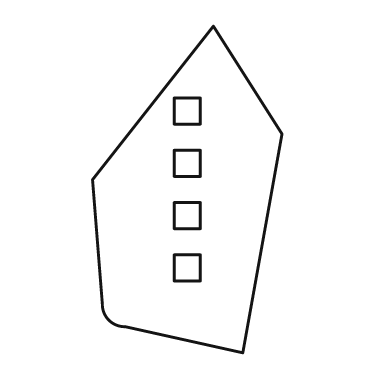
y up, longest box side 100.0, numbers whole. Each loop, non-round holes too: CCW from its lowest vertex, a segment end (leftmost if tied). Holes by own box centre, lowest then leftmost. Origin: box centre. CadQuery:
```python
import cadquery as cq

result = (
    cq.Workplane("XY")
    .moveTo(17.0, -50.0)
    .lineTo(29.0, 17.0)
    .lineTo(8.0, 50.0)
    .lineTo(-29.0, 3.0)
    .lineTo(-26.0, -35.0)
    .threePointArc((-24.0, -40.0), (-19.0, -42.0))
    .close()
    .moveTo(-4.0, -28.0)
    .lineTo(4.0, -28.0)
    .lineTo(4.0, -20.0)
    .lineTo(-4.0, -20.0)
    .close()
    .moveTo(-4.0, -12.0)
    .lineTo(4.0, -12.0)
    .lineTo(4.0, -4.0)
    .lineTo(-4.0, -4.0)
    .close()
    .moveTo(-4.0, 4.0)
    .lineTo(4.0, 4.0)
    .lineTo(4.0, 12.0)
    .lineTo(-4.0, 12.0)
    .close()
    .moveTo(-4.0, 20.0)
    .lineTo(4.0, 20.0)
    .lineTo(4.0, 28.0)
    .lineTo(-4.0, 28.0)
    .close()
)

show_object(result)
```